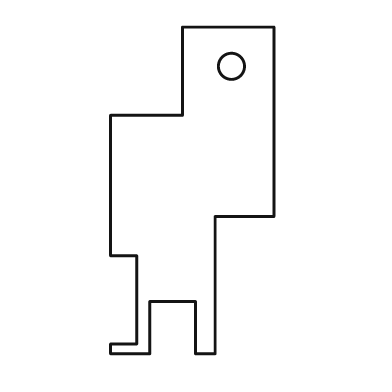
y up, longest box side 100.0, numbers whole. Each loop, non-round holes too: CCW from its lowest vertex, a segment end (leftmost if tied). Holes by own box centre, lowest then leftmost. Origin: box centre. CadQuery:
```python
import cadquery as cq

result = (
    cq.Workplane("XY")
    .moveTo(-25.0, -50.0)
    .lineTo(-13.0, -50.0)
    .lineTo(-13.0, -34.0)
    .lineTo(1.0, -34.0)
    .lineTo(1.0, -50.0)
    .lineTo(7.0, -50.0)
    .lineTo(7.0, -8.0)
    .lineTo(25.0, -8.0)
    .lineTo(25.0, 50.0)
    .lineTo(-3.0, 50.0)
    .lineTo(-3.0, 23.0)
    .lineTo(-25.0, 23.0)
    .lineTo(-25.0, -20.0)
    .lineTo(-17.0, -20.0)
    .lineTo(-17.0, -47.0)
    .lineTo(-25.0, -47.0)
    .close()
    .moveTo(12.0, 38.0)
    .circle(4.0)
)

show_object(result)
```